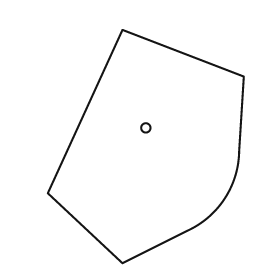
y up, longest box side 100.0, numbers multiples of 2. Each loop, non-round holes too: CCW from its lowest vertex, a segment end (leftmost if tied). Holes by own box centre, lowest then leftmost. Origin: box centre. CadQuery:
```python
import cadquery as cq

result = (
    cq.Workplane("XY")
    .moveTo(-10.0, -50.0)
    .lineTo(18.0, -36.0)
    .threePointArc((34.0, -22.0), (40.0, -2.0))
    .lineTo(42.0, 30.0)
    .lineTo(-10.0, 50.0)
    .lineTo(-42.0, -20.0)
    .close()
    .moveTo(0.0, 8.0)
    .circle(2.0)
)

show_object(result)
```